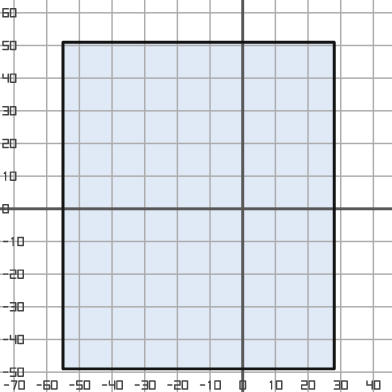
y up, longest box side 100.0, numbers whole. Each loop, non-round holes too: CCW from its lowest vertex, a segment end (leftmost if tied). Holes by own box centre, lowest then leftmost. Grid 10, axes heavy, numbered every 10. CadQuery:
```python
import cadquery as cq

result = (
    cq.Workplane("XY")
    .moveTo(-55.0, -49.0)
    .lineTo(28.0, -49.0)
    .lineTo(28.0, 51.0)
    .lineTo(-55.0, 51.0)
    .close()
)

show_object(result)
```